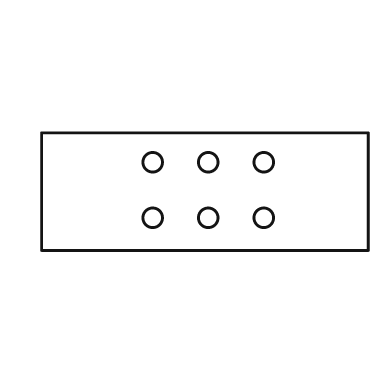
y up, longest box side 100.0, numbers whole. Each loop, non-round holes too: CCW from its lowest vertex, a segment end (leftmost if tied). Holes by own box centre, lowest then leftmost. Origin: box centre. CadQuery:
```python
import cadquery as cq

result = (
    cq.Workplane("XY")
    .moveTo(-50.0, -18.0)
    .lineTo(50.0, -18.0)
    .lineTo(50.0, 18.0)
    .lineTo(-50.0, 18.0)
    .close()
    .moveTo(-16.0, -8.0)
    .circle(3.0)
    .moveTo(1.0, -8.0)
    .circle(3.0)
    .moveTo(18.0, -8.0)
    .circle(3.0)
    .moveTo(-16.0, 9.0)
    .circle(3.0)
    .moveTo(1.0, 9.0)
    .circle(3.0)
    .moveTo(18.0, 9.0)
    .circle(3.0)
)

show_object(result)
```